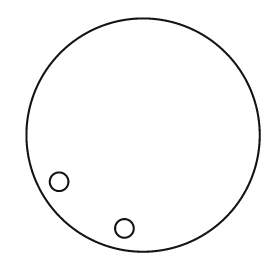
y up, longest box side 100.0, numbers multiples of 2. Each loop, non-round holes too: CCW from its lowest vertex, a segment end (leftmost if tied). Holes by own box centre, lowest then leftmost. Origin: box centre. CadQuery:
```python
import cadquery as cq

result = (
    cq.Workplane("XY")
    .moveTo(0.0, 0.0)
    .circle(50.0)
    .moveTo(-8.0, -40.0)
    .circle(4.0)
    .moveTo(-36.0, -20.0)
    .circle(4.0)
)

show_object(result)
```